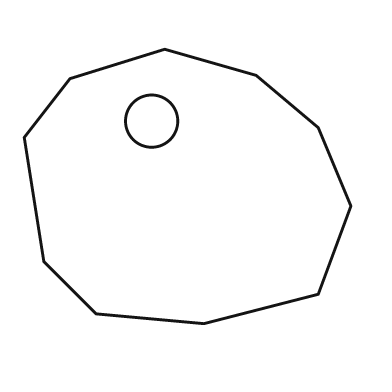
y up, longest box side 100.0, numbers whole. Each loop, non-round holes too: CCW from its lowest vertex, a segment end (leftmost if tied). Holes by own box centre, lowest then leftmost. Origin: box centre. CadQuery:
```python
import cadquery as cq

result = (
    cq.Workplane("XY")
    .moveTo(5.0, -42.0)
    .lineTo(40.0, -33.0)
    .lineTo(50.0, -6.0)
    .lineTo(40.0, 18.0)
    .lineTo(21.0, 34.0)
    .lineTo(-7.0, 42.0)
    .lineTo(-36.0, 33.0)
    .lineTo(-50.0, 15.0)
    .lineTo(-44.0, -23.0)
    .lineTo(-28.0, -39.0)
    .close()
    .moveTo(-11.0, 20.0)
    .circle(8.0)
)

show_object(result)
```